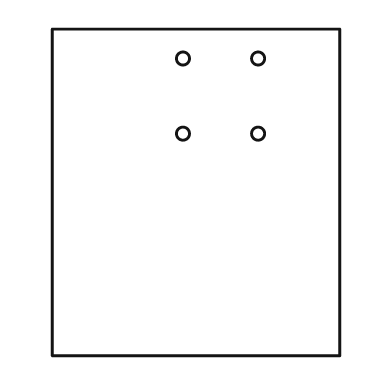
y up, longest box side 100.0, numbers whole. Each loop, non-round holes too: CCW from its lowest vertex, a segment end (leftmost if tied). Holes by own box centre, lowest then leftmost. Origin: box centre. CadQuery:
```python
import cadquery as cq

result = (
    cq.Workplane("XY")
    .moveTo(-44.0, -50.0)
    .lineTo(44.0, -50.0)
    .lineTo(44.0, 50.0)
    .lineTo(-44.0, 50.0)
    .close()
    .moveTo(-4.0, 18.0)
    .circle(2.0)
    .moveTo(19.0, 18.0)
    .circle(2.0)
    .moveTo(-4.0, 41.0)
    .circle(2.0)
    .moveTo(19.0, 41.0)
    .circle(2.0)
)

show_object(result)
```